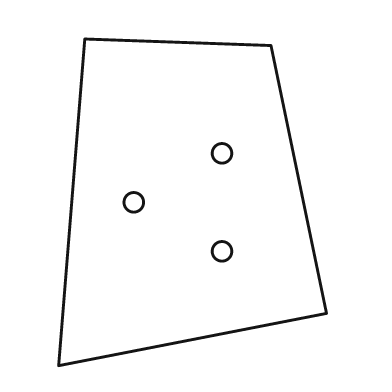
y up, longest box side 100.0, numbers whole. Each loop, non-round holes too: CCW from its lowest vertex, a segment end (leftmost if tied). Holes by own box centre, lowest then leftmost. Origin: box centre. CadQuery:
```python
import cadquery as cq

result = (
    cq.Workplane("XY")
    .moveTo(-41.0, -50.0)
    .lineTo(41.0, -34.0)
    .lineTo(24.0, 48.0)
    .lineTo(-33.0, 50.0)
    .close()
    .moveTo(9.0, -15.0)
    .circle(3.0)
    .moveTo(-18.0, 0.0)
    .circle(3.0)
    .moveTo(9.0, 15.0)
    .circle(3.0)
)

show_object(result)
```